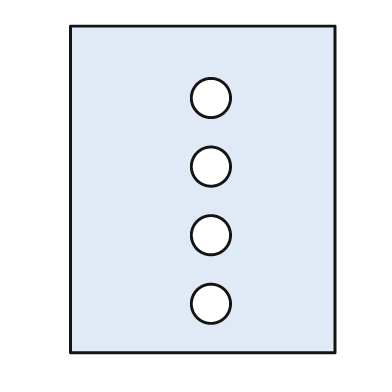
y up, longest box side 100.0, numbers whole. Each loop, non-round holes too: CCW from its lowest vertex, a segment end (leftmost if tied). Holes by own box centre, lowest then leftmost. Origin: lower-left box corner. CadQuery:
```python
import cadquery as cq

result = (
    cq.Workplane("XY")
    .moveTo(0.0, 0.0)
    .lineTo(81.0, 0.0)
    .lineTo(81.0, 100.0)
    .lineTo(0.0, 100.0)
    .close()
    .moveTo(43.0, 15.0)
    .circle(6.0)
    .moveTo(43.0, 36.0)
    .circle(6.0)
    .moveTo(43.0, 57.0)
    .circle(6.0)
    .moveTo(43.0, 78.0)
    .circle(6.0)
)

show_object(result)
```